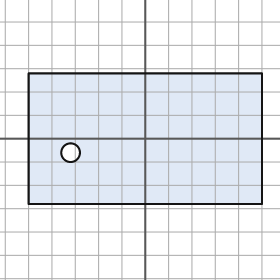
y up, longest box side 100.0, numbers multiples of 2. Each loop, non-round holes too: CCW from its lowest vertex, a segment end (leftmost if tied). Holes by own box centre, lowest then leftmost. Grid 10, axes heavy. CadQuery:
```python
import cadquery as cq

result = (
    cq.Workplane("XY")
    .moveTo(-50.0, -28.0)
    .lineTo(50.0, -28.0)
    .lineTo(50.0, 28.0)
    .lineTo(-50.0, 28.0)
    .close()
    .moveTo(-32.0, -6.0)
    .circle(4.0)
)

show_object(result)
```